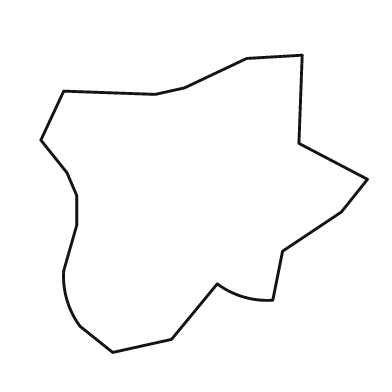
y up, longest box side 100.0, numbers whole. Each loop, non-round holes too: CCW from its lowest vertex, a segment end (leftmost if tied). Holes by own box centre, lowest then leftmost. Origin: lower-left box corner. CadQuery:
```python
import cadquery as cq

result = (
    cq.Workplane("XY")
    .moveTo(22.0, 0.0)
    .lineTo(40.0, 4.0)
    .lineTo(54.0, 21.0)
    .threePointArc((62.0, 17.0), (71.0, 16.0))
    .lineTo(74.0, 31.0)
    .lineTo(92.0, 43.0)
    .lineTo(100.0, 53.0)
    .lineTo(79.0, 64.0)
    .lineTo(80.0, 91.0)
    .lineTo(63.0, 90.0)
    .lineTo(44.0, 81.0)
    .lineTo(35.0, 79.0)
    .lineTo(7.0, 80.0)
    .lineTo(0.0, 65.0)
    .lineTo(8.0, 55.0)
    .lineTo(11.0, 48.0)
    .lineTo(11.0, 39.0)
    .lineTo(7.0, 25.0)
    .threePointArc((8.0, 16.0), (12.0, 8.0))
    .close()
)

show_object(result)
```